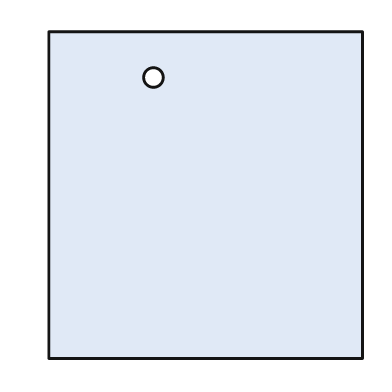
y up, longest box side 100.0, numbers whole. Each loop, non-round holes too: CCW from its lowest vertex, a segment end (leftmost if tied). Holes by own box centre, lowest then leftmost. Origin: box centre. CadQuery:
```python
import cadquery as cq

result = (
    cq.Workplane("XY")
    .moveTo(-48.0, -50.0)
    .lineTo(48.0, -50.0)
    .lineTo(48.0, 50.0)
    .lineTo(-48.0, 50.0)
    .close()
    .moveTo(-16.0, 36.0)
    .circle(3.0)
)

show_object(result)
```